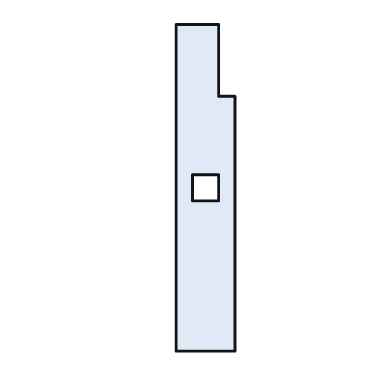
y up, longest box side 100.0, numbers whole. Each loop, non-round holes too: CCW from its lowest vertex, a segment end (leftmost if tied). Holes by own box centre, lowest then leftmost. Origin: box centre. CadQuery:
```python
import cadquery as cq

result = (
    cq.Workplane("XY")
    .moveTo(-9.0, -50.0)
    .lineTo(9.0, -50.0)
    .lineTo(9.0, 28.0)
    .lineTo(4.0, 28.0)
    .lineTo(4.0, 50.0)
    .lineTo(-9.0, 50.0)
    .close()
    .moveTo(-4.0, -4.0)
    .lineTo(4.0, -4.0)
    .lineTo(4.0, 4.0)
    .lineTo(-4.0, 4.0)
    .close()
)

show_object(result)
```